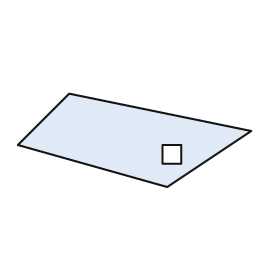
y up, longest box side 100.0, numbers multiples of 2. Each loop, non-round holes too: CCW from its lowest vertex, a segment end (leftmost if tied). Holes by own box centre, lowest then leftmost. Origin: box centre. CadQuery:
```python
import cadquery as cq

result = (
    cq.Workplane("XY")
    .moveTo(14.0, -20.0)
    .lineTo(50.0, 4.0)
    .lineTo(-28.0, 20.0)
    .lineTo(-50.0, -2.0)
    .close()
    .moveTo(12.0, -10.0)
    .lineTo(20.0, -10.0)
    .lineTo(20.0, -2.0)
    .lineTo(12.0, -2.0)
    .close()
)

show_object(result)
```